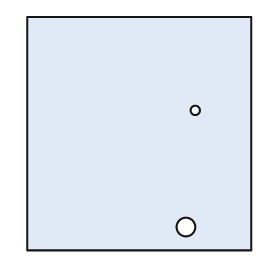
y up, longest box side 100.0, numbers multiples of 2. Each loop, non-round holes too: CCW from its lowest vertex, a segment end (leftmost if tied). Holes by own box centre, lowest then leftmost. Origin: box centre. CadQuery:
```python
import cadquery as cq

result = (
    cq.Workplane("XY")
    .moveTo(-48.0, -50.0)
    .lineTo(48.0, -50.0)
    .lineTo(48.0, 50.0)
    .lineTo(-48.0, 50.0)
    .close()
    .moveTo(20.0, -40.0)
    .circle(4.0)
    .moveTo(24.0, 10.0)
    .circle(2.0)
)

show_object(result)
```